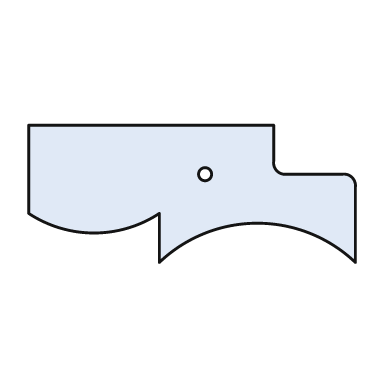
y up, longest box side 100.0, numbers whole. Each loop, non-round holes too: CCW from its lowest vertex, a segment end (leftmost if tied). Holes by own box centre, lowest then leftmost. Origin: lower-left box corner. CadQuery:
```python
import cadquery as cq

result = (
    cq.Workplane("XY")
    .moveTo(40.0, 0.0)
    .threePointArc((70.0, 12.0), (100.0, 0.0))
    .lineTo(100.0, 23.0)
    .threePointArc((99.0, 26.0), (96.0, 27.0))
    .lineTo(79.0, 27.0)
    .threePointArc((76.0, 28.0), (75.0, 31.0))
    .lineTo(75.0, 42.0)
    .lineTo(0.0, 42.0)
    .lineTo(0.0, 15.0)
    .threePointArc((20.0, 9.0), (40.0, 15.0))
    .close()
    .moveTo(54.0, 27.0)
    .circle(2.0)
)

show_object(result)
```